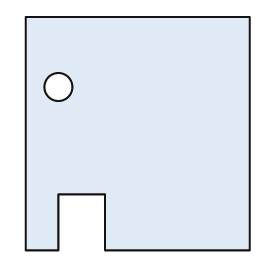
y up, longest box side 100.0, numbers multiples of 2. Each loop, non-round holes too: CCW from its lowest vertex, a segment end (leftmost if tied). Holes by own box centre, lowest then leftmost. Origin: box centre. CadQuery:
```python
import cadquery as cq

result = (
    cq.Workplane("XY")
    .moveTo(-48.0, -50.0)
    .lineTo(-34.0, -50.0)
    .lineTo(-34.0, -26.0)
    .lineTo(-14.0, -26.0)
    .lineTo(-14.0, -50.0)
    .lineTo(48.0, -50.0)
    .lineTo(48.0, 50.0)
    .lineTo(-48.0, 50.0)
    .close()
    .moveTo(-34.0, 20.0)
    .circle(6.0)
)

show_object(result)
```